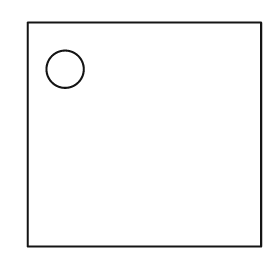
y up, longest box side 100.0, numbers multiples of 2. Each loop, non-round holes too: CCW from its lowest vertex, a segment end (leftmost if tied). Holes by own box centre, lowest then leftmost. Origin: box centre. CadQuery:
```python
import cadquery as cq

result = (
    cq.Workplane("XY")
    .moveTo(-50.0, -48.0)
    .lineTo(50.0, -48.0)
    .lineTo(50.0, 48.0)
    .lineTo(-50.0, 48.0)
    .close()
    .moveTo(-34.0, 28.0)
    .circle(8.0)
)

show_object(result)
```